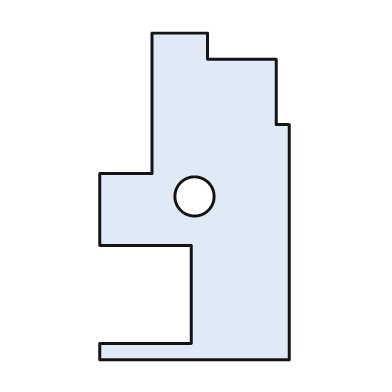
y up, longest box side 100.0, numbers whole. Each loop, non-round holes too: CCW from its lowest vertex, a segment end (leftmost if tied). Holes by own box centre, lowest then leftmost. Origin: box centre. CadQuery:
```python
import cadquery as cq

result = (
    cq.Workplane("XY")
    .moveTo(-29.0, -50.0)
    .lineTo(29.0, -50.0)
    .lineTo(29.0, 22.0)
    .lineTo(25.0, 22.0)
    .lineTo(25.0, 42.0)
    .lineTo(4.0, 42.0)
    .lineTo(4.0, 50.0)
    .lineTo(-13.0, 50.0)
    .lineTo(-13.0, 7.0)
    .lineTo(-29.0, 7.0)
    .lineTo(-29.0, -15.0)
    .lineTo(-1.0, -15.0)
    .lineTo(-1.0, -45.0)
    .lineTo(-29.0, -45.0)
    .close()
    .moveTo(0.0, 0.0)
    .circle(6.0)
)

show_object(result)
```